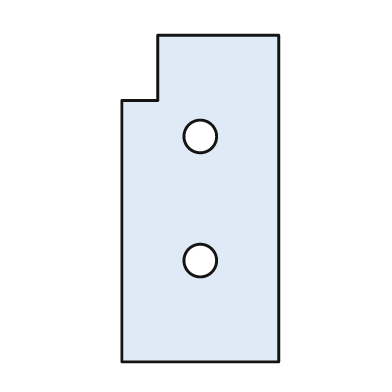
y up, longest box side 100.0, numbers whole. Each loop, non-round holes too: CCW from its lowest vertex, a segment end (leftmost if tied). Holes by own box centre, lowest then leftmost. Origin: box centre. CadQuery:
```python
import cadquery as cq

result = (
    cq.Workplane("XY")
    .moveTo(-24.0, -50.0)
    .lineTo(24.0, -50.0)
    .lineTo(24.0, 50.0)
    .lineTo(-13.0, 50.0)
    .lineTo(-13.0, 30.0)
    .lineTo(-24.0, 30.0)
    .close()
    .moveTo(0.0, -19.0)
    .circle(5.0)
    .moveTo(0.0, 19.0)
    .circle(5.0)
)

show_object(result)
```